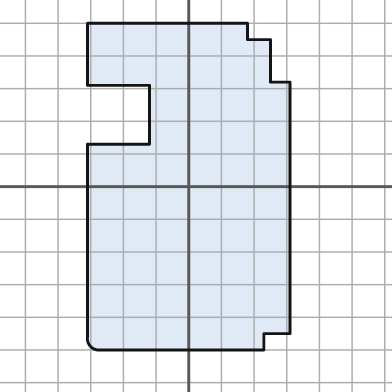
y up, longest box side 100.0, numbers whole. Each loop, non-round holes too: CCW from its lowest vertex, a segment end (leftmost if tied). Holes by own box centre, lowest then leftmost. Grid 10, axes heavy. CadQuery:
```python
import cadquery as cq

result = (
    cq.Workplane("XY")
    .moveTo(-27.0, -50.0)
    .lineTo(23.0, -50.0)
    .lineTo(23.0, -45.0)
    .lineTo(31.0, -45.0)
    .lineTo(31.0, 32.0)
    .lineTo(25.0, 32.0)
    .lineTo(25.0, 45.0)
    .lineTo(18.0, 45.0)
    .lineTo(18.0, 50.0)
    .lineTo(-31.0, 50.0)
    .lineTo(-31.0, 31.0)
    .lineTo(-12.0, 31.0)
    .lineTo(-12.0, 13.0)
    .lineTo(-31.0, 13.0)
    .lineTo(-31.0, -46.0)
    .threePointArc((-30.0, -49.0), (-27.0, -50.0))
    .close()
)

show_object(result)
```